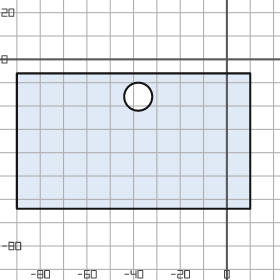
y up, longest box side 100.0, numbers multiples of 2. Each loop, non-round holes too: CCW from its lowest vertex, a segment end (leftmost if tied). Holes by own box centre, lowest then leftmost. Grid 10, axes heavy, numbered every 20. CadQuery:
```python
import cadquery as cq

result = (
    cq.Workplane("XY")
    .moveTo(-90.0, -64.0)
    .lineTo(10.0, -64.0)
    .lineTo(10.0, -6.0)
    .lineTo(-90.0, -6.0)
    .close()
    .moveTo(-38.0, -16.0)
    .circle(6.0)
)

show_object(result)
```